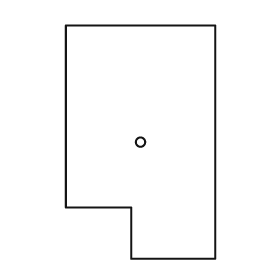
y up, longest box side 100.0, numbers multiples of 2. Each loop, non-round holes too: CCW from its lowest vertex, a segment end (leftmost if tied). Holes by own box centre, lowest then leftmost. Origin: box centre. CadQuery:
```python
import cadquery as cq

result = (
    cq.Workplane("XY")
    .moveTo(-4.0, -50.0)
    .lineTo(32.0, -50.0)
    .lineTo(32.0, 50.0)
    .lineTo(-32.0, 50.0)
    .lineTo(-32.0, -28.0)
    .lineTo(-4.0, -28.0)
    .close()
    .moveTo(0.0, 0.0)
    .circle(2.0)
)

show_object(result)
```